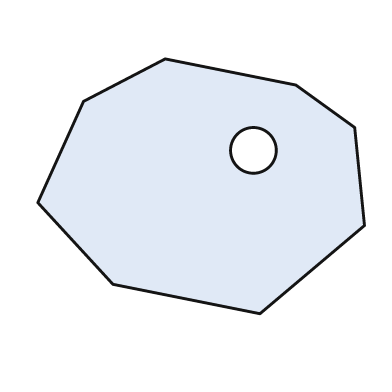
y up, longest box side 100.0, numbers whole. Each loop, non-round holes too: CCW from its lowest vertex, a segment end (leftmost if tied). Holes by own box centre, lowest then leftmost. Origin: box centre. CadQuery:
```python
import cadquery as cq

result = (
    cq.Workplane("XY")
    .moveTo(18.0, -39.0)
    .lineTo(50.0, -12.0)
    .lineTo(47.0, 18.0)
    .lineTo(29.0, 31.0)
    .lineTo(-11.0, 39.0)
    .lineTo(-36.0, 26.0)
    .lineTo(-50.0, -5.0)
    .lineTo(-27.0, -30.0)
    .close()
    .moveTo(16.0, 11.0)
    .circle(7.0)
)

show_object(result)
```